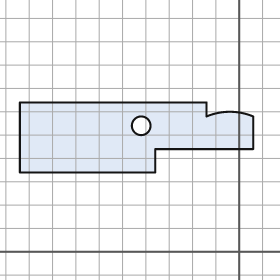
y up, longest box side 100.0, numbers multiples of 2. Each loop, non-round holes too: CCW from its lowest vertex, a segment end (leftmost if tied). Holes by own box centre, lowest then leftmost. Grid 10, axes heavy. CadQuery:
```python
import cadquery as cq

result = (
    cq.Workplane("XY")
    .moveTo(-94.0, 34.0)
    .lineTo(-36.0, 34.0)
    .lineTo(-36.0, 44.0)
    .lineTo(6.0, 44.0)
    .lineTo(6.0, 58.0)
    .threePointArc((-4.0, 60.0), (-14.0, 58.0))
    .lineTo(-14.0, 64.0)
    .lineTo(-94.0, 64.0)
    .close()
    .moveTo(-42.0, 54.0)
    .circle(4.0)
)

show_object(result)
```